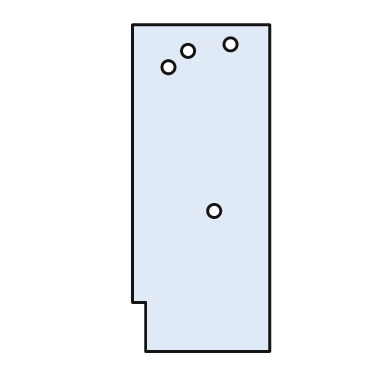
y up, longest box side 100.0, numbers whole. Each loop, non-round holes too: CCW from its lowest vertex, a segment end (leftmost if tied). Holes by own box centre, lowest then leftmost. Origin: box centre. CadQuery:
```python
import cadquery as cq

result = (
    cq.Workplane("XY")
    .moveTo(-17.0, -50.0)
    .lineTo(21.0, -50.0)
    .lineTo(21.0, 50.0)
    .lineTo(-21.0, 50.0)
    .lineTo(-21.0, -35.0)
    .lineTo(-17.0, -35.0)
    .close()
    .moveTo(4.0, -7.0)
    .circle(2.0)
    .moveTo(-10.0, 37.0)
    .circle(2.0)
    .moveTo(-4.0, 42.0)
    .circle(2.0)
    .moveTo(9.0, 44.0)
    .circle(2.0)
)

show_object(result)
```